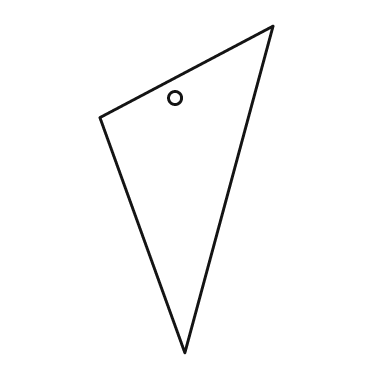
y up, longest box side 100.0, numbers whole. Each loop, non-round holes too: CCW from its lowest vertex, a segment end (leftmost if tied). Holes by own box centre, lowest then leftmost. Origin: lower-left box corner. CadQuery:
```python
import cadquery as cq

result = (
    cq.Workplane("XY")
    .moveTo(26.0, 0.0)
    .lineTo(53.0, 100.0)
    .lineTo(0.0, 72.0)
    .close()
    .moveTo(23.0, 78.0)
    .circle(2.0)
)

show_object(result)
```